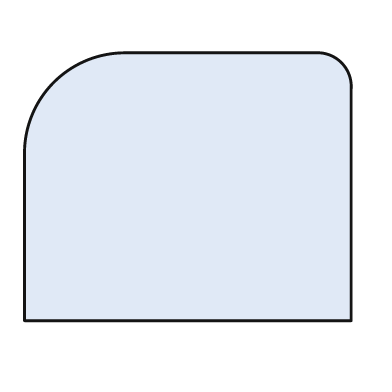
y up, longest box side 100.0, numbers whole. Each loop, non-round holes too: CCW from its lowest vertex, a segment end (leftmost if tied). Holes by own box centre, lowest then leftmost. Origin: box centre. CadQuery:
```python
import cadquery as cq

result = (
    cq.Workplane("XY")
    .moveTo(-50.0, -41.0)
    .lineTo(50.0, -41.0)
    .lineTo(50.0, 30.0)
    .threePointArc((47.0, 38.0), (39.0, 41.0))
    .lineTo(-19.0, 41.0)
    .threePointArc((-41.0, 32.0), (-50.0, 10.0))
    .close()
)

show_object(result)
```